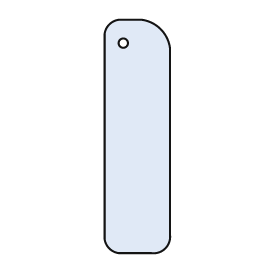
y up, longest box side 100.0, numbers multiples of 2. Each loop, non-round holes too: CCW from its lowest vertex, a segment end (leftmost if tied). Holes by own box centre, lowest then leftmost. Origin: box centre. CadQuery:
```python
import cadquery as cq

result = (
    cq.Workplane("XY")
    .moveTo(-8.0, -50.0)
    .lineTo(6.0, -50.0)
    .threePointArc((12.0, -48.0), (14.0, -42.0))
    .lineTo(14.0, 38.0)
    .threePointArc((10.0, 46.0), (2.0, 50.0))
    .lineTo(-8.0, 50.0)
    .threePointArc((-12.0, 48.0), (-14.0, 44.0))
    .lineTo(-14.0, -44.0)
    .threePointArc((-12.0, -48.0), (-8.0, -50.0))
    .close()
    .moveTo(-6.0, 40.0)
    .circle(2.0)
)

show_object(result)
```